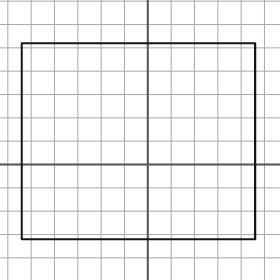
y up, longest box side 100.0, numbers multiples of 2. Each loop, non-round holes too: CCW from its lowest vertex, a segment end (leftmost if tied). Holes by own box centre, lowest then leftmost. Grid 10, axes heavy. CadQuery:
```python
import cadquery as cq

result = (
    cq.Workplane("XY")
    .moveTo(-54.0, -32.0)
    .lineTo(46.0, -32.0)
    .lineTo(46.0, 52.0)
    .lineTo(-54.0, 52.0)
    .close()
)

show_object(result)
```